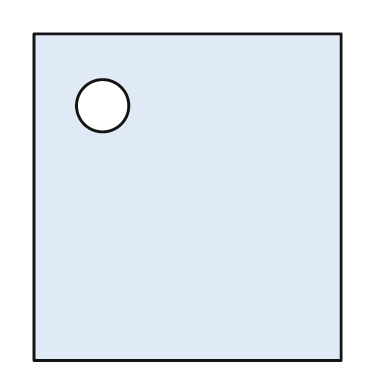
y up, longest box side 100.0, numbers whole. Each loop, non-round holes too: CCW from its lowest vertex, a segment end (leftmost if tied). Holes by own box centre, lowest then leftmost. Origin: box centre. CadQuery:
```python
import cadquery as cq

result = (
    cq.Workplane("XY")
    .moveTo(-47.0, -50.0)
    .lineTo(47.0, -50.0)
    .lineTo(47.0, 50.0)
    .lineTo(-47.0, 50.0)
    .close()
    .moveTo(-26.0, 28.0)
    .circle(8.0)
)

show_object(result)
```